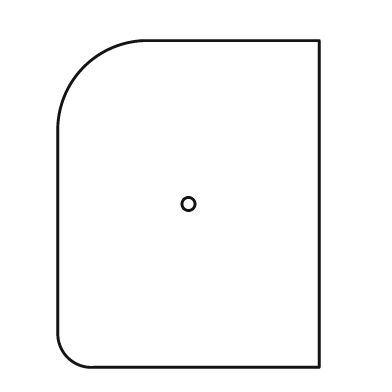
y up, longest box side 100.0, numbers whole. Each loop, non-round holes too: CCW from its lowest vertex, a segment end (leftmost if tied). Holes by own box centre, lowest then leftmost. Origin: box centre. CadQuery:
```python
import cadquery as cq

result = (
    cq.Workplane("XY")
    .moveTo(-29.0, -50.0)
    .lineTo(40.0, -50.0)
    .lineTo(40.0, 50.0)
    .lineTo(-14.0, 50.0)
    .threePointArc((-32.0, 42.0), (-40.0, 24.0))
    .lineTo(-40.0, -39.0)
    .threePointArc((-37.0, -47.0), (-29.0, -50.0))
    .close()
    .moveTo(0.0, 0.0)
    .circle(2.0)
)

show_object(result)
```